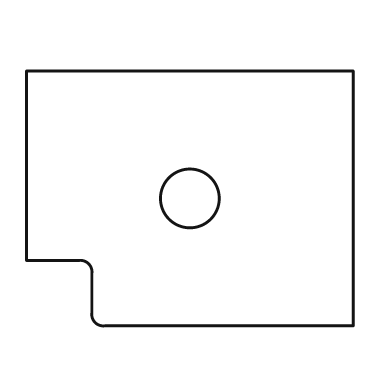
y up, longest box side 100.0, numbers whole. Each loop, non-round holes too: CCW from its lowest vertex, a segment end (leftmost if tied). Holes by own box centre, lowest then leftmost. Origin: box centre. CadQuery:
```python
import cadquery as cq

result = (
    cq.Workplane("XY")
    .moveTo(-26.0, -39.0)
    .lineTo(50.0, -39.0)
    .lineTo(50.0, 39.0)
    .lineTo(-50.0, 39.0)
    .lineTo(-50.0, -19.0)
    .lineTo(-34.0, -19.0)
    .threePointArc((-31.0, -20.0), (-30.0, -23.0))
    .lineTo(-30.0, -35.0)
    .threePointArc((-29.0, -38.0), (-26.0, -39.0))
    .close()
    .moveTo(0.0, 0.0)
    .circle(9.0)
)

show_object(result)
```